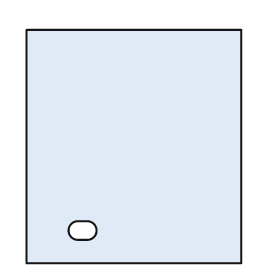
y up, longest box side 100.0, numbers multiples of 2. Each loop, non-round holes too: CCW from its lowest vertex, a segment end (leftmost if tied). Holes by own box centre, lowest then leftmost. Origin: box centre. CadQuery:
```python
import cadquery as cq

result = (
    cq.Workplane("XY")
    .moveTo(-46.0, -50.0)
    .lineTo(46.0, -50.0)
    .lineTo(46.0, 50.0)
    .lineTo(-46.0, 50.0)
    .close()
    .moveTo(-24.0, -40.0)
    .lineTo(-20.0, -40.0)
    .threePointArc((-16.0, -36.0), (-20.0, -32.0))
    .lineTo(-24.0, -32.0)
    .threePointArc((-28.0, -36.0), (-24.0, -40.0))
    .close()
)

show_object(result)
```